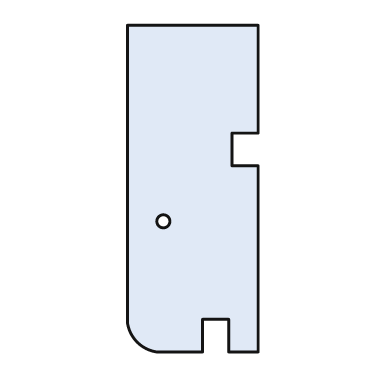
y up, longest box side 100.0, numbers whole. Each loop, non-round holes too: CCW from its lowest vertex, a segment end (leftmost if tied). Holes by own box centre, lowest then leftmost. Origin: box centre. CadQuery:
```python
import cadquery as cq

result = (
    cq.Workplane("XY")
    .moveTo(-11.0, -50.0)
    .lineTo(3.0, -50.0)
    .lineTo(3.0, -40.0)
    .lineTo(11.0, -40.0)
    .lineTo(11.0, -50.0)
    .lineTo(20.0, -50.0)
    .lineTo(20.0, 7.0)
    .lineTo(12.0, 7.0)
    .lineTo(12.0, 17.0)
    .lineTo(20.0, 17.0)
    .lineTo(20.0, 50.0)
    .lineTo(-20.0, 50.0)
    .lineTo(-20.0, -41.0)
    .threePointArc((-17.0, -47.0), (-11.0, -50.0))
    .close()
    .moveTo(-9.0, -10.0)
    .circle(2.0)
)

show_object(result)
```